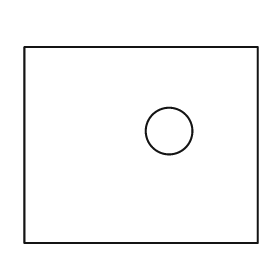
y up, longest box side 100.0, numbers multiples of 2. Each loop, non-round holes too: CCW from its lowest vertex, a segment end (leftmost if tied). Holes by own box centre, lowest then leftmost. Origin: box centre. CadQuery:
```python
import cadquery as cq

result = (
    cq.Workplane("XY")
    .moveTo(-50.0, -42.0)
    .lineTo(50.0, -42.0)
    .lineTo(50.0, 42.0)
    .lineTo(-50.0, 42.0)
    .close()
    .moveTo(12.0, 6.0)
    .circle(10.0)
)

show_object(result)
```